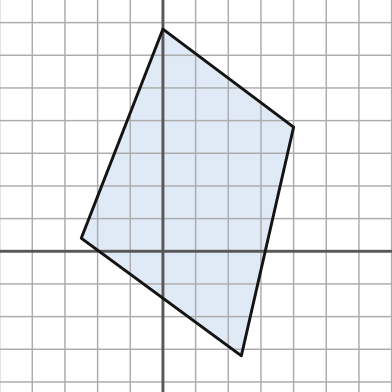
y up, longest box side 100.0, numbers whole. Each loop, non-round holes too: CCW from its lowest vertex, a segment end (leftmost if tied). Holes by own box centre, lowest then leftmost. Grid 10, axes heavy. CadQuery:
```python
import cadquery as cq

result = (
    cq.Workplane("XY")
    .moveTo(24.0, -32.0)
    .lineTo(40.0, 38.0)
    .lineTo(0.0, 68.0)
    .lineTo(-25.0, 4.0)
    .close()
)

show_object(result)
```